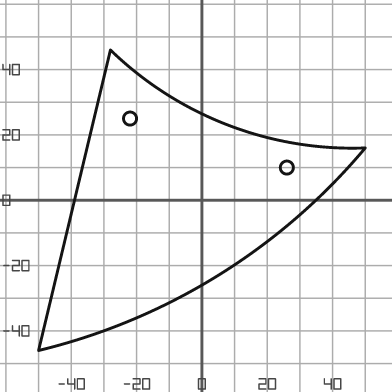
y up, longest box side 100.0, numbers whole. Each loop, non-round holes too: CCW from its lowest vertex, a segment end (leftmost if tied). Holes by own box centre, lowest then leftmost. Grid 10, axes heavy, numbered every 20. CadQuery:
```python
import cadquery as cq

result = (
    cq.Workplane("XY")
    .moveTo(-50.0, -46.0)
    .threePointArc((5.0, -23.0), (50.0, 16.0))
    .threePointArc((8.0, 23.0), (-28.0, 46.0))
    .close()
    .moveTo(26.0, 10.0)
    .circle(2.0)
    .moveTo(-22.0, 25.0)
    .circle(2.0)
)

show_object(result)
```